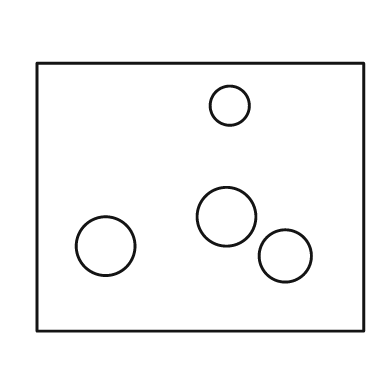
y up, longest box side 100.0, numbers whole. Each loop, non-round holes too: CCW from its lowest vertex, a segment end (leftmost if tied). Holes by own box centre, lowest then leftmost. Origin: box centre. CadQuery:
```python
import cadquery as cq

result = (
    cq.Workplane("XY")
    .moveTo(-50.0, -41.0)
    .lineTo(50.0, -41.0)
    .lineTo(50.0, 41.0)
    .lineTo(-50.0, 41.0)
    .close()
    .moveTo(26.0, -18.0)
    .circle(8.0)
    .moveTo(-29.0, -15.0)
    .circle(9.0)
    .moveTo(8.0, -6.0)
    .circle(9.0)
    .moveTo(9.0, 28.0)
    .circle(6.0)
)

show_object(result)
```